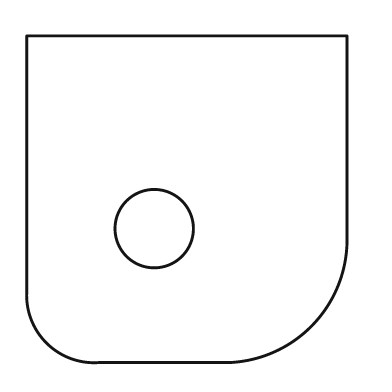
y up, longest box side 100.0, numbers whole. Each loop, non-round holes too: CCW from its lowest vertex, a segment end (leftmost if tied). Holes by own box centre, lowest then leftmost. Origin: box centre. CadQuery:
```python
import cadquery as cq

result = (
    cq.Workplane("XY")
    .moveTo(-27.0, -50.0)
    .lineTo(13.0, -50.0)
    .threePointArc((38.0, -39.0), (49.0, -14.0))
    .lineTo(49.0, 50.0)
    .lineTo(-49.0, 50.0)
    .lineTo(-49.0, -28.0)
    .threePointArc((-43.0, -44.0), (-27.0, -50.0))
    .close()
    .moveTo(-10.0, -9.0)
    .circle(12.0)
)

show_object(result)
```